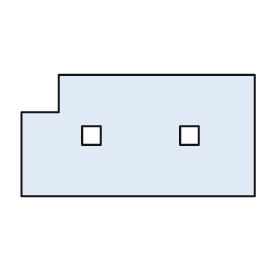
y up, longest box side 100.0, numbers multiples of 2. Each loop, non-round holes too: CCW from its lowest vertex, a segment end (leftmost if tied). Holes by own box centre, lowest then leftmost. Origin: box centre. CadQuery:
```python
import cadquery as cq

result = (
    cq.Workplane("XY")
    .moveTo(-50.0, -26.0)
    .lineTo(50.0, -26.0)
    .lineTo(50.0, 26.0)
    .lineTo(-34.0, 26.0)
    .lineTo(-34.0, 10.0)
    .lineTo(-50.0, 10.0)
    .close()
    .moveTo(-24.0, -4.0)
    .lineTo(-16.0, -4.0)
    .lineTo(-16.0, 4.0)
    .lineTo(-24.0, 4.0)
    .close()
    .moveTo(18.0, -4.0)
    .lineTo(26.0, -4.0)
    .lineTo(26.0, 4.0)
    .lineTo(18.0, 4.0)
    .close()
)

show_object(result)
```